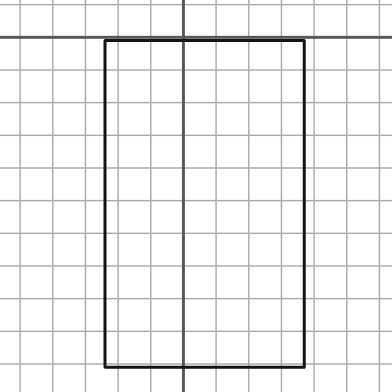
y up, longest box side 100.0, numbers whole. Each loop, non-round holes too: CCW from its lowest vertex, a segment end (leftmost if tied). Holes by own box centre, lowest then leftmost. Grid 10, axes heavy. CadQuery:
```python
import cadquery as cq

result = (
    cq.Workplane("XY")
    .moveTo(-24.0, -101.0)
    .lineTo(37.0, -101.0)
    .lineTo(37.0, -1.0)
    .lineTo(-24.0, -1.0)
    .close()
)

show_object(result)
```